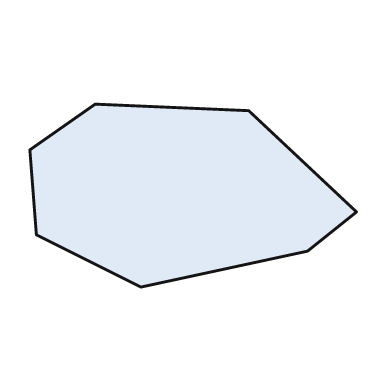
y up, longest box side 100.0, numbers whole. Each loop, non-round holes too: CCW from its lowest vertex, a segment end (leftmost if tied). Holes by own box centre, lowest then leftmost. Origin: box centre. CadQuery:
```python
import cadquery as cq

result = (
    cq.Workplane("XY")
    .moveTo(-16.0, -28.0)
    .lineTo(35.0, -17.0)
    .lineTo(50.0, -5.0)
    .lineTo(17.0, 26.0)
    .lineTo(-30.0, 28.0)
    .lineTo(-50.0, 14.0)
    .lineTo(-48.0, -12.0)
    .close()
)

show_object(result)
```